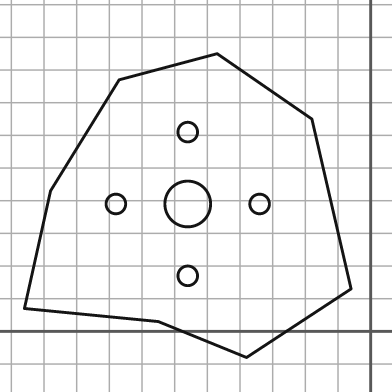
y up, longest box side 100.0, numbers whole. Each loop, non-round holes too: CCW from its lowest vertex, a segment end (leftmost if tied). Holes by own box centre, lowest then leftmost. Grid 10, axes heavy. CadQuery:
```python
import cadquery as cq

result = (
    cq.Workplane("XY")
    .moveTo(-38.0, -8.0)
    .lineTo(-6.0, 13.0)
    .lineTo(-18.0, 65.0)
    .lineTo(-47.0, 85.0)
    .lineTo(-77.0, 77.0)
    .lineTo(-98.0, 43.0)
    .lineTo(-106.0, 7.0)
    .lineTo(-65.0, 3.0)
    .close()
    .moveTo(-56.0, 17.0)
    .circle(3.0)
    .moveTo(-78.0, 39.0)
    .circle(3.0)
    .moveTo(-56.0, 39.0)
    .circle(7.0)
    .moveTo(-34.0, 39.0)
    .circle(3.0)
    .moveTo(-56.0, 61.0)
    .circle(3.0)
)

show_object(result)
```